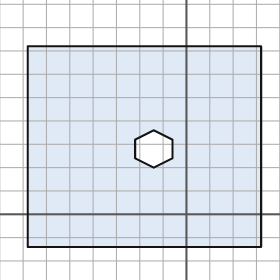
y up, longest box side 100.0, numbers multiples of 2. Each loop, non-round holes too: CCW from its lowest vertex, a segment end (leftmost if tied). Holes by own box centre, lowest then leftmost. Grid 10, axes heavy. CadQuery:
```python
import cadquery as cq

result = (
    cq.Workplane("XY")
    .moveTo(-68.0, -14.0)
    .lineTo(32.0, -14.0)
    .lineTo(32.0, 72.0)
    .lineTo(-68.0, 72.0)
    .close()
    .moveTo(-14.0, 20.0)
    .lineTo(-6.0, 24.0)
    .lineTo(-6.0, 32.0)
    .lineTo(-14.0, 36.0)
    .lineTo(-22.0, 32.0)
    .lineTo(-22.0, 24.0)
    .close()
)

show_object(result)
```